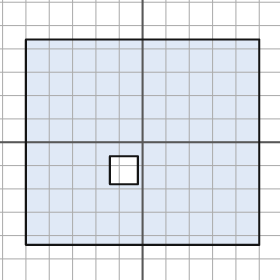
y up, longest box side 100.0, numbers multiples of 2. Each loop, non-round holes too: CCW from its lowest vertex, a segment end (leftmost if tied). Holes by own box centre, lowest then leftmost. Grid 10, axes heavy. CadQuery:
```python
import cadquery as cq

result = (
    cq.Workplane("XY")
    .moveTo(-50.0, -44.0)
    .lineTo(50.0, -44.0)
    .lineTo(50.0, 44.0)
    .lineTo(-50.0, 44.0)
    .close()
    .moveTo(-14.0, -18.0)
    .lineTo(-2.0, -18.0)
    .lineTo(-2.0, -6.0)
    .lineTo(-14.0, -6.0)
    .close()
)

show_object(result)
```